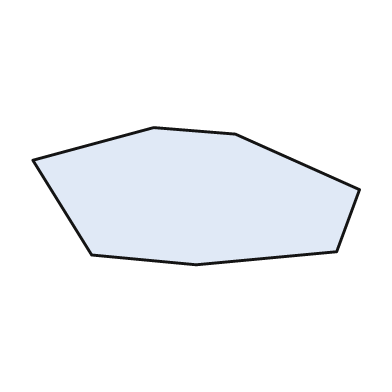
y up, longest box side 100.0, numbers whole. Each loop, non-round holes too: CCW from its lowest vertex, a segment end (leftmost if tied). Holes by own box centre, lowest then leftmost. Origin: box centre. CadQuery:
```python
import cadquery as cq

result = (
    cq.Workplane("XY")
    .moveTo(0.0, -21.0)
    .lineTo(43.0, -17.0)
    .lineTo(50.0, 2.0)
    .lineTo(12.0, 19.0)
    .lineTo(-13.0, 21.0)
    .lineTo(-50.0, 11.0)
    .lineTo(-32.0, -18.0)
    .close()
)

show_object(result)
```